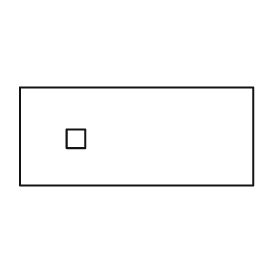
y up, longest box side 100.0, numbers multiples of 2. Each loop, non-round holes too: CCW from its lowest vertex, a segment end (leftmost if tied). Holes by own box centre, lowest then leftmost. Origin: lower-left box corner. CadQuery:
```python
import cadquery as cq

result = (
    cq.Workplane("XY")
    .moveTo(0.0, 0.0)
    .lineTo(100.0, 0.0)
    .lineTo(100.0, 42.0)
    .lineTo(0.0, 42.0)
    .close()
    .moveTo(20.0, 16.0)
    .lineTo(28.0, 16.0)
    .lineTo(28.0, 24.0)
    .lineTo(20.0, 24.0)
    .close()
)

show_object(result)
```